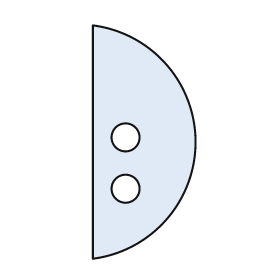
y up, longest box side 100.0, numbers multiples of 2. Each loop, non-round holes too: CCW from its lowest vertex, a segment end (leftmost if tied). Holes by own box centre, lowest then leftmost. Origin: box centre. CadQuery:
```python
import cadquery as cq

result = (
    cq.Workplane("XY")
    .moveTo(-22.0, -50.0)
    .threePointArc((22.0, 0.0), (-22.0, 50.0))
    .close()
    .moveTo(-8.0, -20.0)
    .circle(6.0)
    .moveTo(-8.0, 2.0)
    .circle(6.0)
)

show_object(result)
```